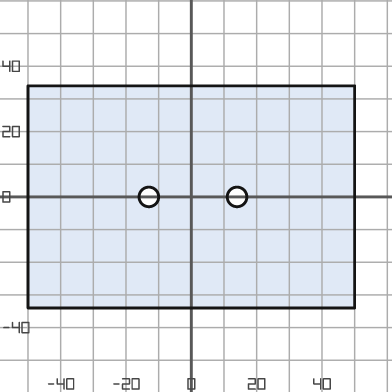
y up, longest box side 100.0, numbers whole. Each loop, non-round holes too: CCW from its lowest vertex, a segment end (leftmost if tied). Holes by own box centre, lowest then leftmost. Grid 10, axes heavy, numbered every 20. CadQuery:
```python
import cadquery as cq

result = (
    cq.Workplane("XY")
    .moveTo(-50.0, -34.0)
    .lineTo(50.0, -34.0)
    .lineTo(50.0, 34.0)
    .lineTo(-50.0, 34.0)
    .close()
    .moveTo(-13.0, 0.0)
    .circle(3.0)
    .moveTo(14.0, 0.0)
    .circle(3.0)
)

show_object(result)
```